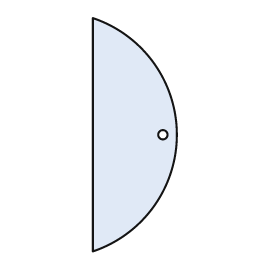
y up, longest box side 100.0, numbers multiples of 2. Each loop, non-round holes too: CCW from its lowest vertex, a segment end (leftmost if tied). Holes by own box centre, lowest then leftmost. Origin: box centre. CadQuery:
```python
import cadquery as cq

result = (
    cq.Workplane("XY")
    .moveTo(-18.0, -50.0)
    .threePointArc((18.0, 0.0), (-18.0, 50.0))
    .close()
    .moveTo(12.0, 0.0)
    .circle(2.0)
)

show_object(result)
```